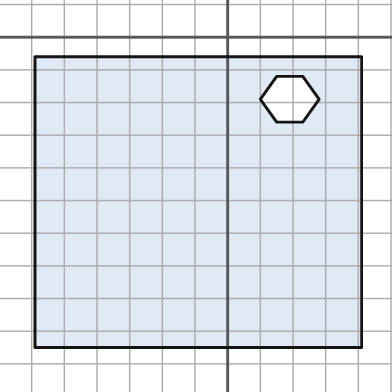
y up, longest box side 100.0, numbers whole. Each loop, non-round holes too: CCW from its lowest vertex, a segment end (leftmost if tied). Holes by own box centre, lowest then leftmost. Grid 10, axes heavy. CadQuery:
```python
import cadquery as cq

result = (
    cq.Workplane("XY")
    .moveTo(-59.0, -95.0)
    .lineTo(41.0, -95.0)
    .lineTo(41.0, -6.0)
    .lineTo(-59.0, -6.0)
    .close()
    .moveTo(15.0, -26.0)
    .lineTo(23.0, -26.0)
    .lineTo(28.0, -19.0)
    .lineTo(23.0, -12.0)
    .lineTo(15.0, -12.0)
    .lineTo(10.0, -19.0)
    .close()
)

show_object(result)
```